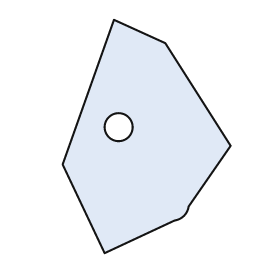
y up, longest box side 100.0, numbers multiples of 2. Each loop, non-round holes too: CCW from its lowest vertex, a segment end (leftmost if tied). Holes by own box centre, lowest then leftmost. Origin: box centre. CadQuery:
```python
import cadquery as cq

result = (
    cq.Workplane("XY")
    .moveTo(-18.0, -50.0)
    .lineTo(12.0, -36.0)
    .threePointArc((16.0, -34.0), (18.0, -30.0))
    .lineTo(36.0, -4.0)
    .lineTo(8.0, 40.0)
    .lineTo(-14.0, 50.0)
    .lineTo(-36.0, -12.0)
    .close()
    .moveTo(-12.0, 4.0)
    .circle(6.0)
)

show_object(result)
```